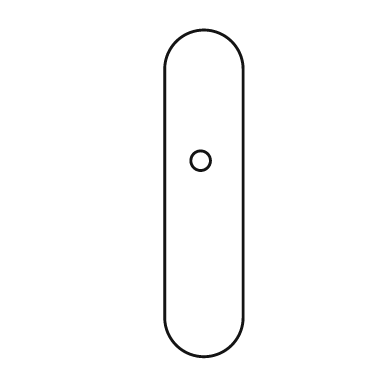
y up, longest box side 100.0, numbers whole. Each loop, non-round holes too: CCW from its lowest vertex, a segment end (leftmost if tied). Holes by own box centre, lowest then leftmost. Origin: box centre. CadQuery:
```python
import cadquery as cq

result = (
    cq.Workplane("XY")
    .moveTo(-12.0, -38.0)
    .threePointArc((0.0, -50.0), (12.0, -38.0))
    .lineTo(12.0, 38.0)
    .threePointArc((0.0, 50.0), (-12.0, 38.0))
    .close()
    .moveTo(-1.0, 10.0)
    .circle(3.0)
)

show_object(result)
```